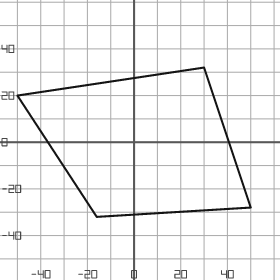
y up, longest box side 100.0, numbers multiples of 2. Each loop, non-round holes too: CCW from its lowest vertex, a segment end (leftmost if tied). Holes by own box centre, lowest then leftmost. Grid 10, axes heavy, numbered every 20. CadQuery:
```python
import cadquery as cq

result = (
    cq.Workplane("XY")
    .moveTo(-16.0, -32.0)
    .lineTo(50.0, -28.0)
    .lineTo(30.0, 32.0)
    .lineTo(-50.0, 20.0)
    .close()
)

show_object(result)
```